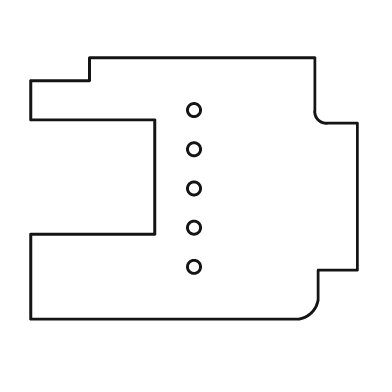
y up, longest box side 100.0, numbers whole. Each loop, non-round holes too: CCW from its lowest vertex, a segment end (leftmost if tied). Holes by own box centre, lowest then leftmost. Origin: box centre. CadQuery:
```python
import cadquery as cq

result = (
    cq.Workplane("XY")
    .moveTo(-50.0, -40.0)
    .lineTo(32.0, -40.0)
    .threePointArc((36.0, -38.0), (38.0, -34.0))
    .lineTo(38.0, -25.0)
    .lineTo(50.0, -25.0)
    .lineTo(50.0, 20.0)
    .lineTo(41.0, 20.0)
    .threePointArc((38.0, 21.0), (37.0, 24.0))
    .lineTo(37.0, 40.0)
    .lineTo(-32.0, 40.0)
    .lineTo(-32.0, 33.0)
    .lineTo(-50.0, 33.0)
    .lineTo(-50.0, 21.0)
    .lineTo(-12.0, 21.0)
    .lineTo(-12.0, -14.0)
    .lineTo(-50.0, -14.0)
    .close()
    .moveTo(0.0, -24.0)
    .circle(2.0)
    .moveTo(0.0, -12.0)
    .circle(2.0)
    .moveTo(0.0, 0.0)
    .circle(2.0)
    .moveTo(0.0, 12.0)
    .circle(2.0)
    .moveTo(0.0, 24.0)
    .circle(2.0)
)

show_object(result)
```